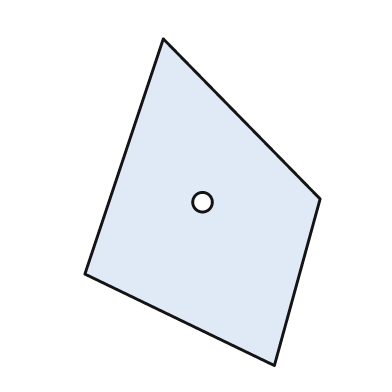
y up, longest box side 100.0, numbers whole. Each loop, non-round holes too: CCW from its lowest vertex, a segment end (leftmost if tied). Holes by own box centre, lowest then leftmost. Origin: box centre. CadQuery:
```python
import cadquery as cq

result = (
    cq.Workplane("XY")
    .moveTo(22.0, -50.0)
    .lineTo(36.0, 1.0)
    .lineTo(-12.0, 50.0)
    .lineTo(-36.0, -22.0)
    .close()
    .moveTo(0.0, 0.0)
    .circle(3.0)
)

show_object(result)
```